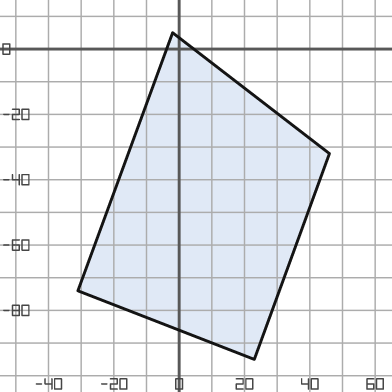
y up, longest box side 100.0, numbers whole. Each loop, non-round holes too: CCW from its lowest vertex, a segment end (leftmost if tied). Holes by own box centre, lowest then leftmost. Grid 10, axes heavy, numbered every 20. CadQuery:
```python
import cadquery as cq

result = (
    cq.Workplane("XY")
    .moveTo(23.0, -95.0)
    .lineTo(46.0, -32.0)
    .lineTo(-2.0, 5.0)
    .lineTo(-31.0, -74.0)
    .close()
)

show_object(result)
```